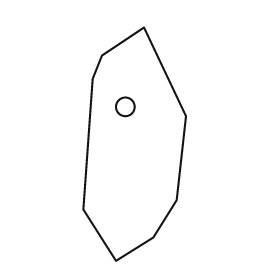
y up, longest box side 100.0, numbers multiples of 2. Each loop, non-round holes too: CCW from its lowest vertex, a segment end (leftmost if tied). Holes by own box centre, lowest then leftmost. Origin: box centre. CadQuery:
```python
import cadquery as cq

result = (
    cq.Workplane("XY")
    .moveTo(-8.0, -50.0)
    .lineTo(8.0, -40.0)
    .lineTo(18.0, -24.0)
    .lineTo(22.0, 12.0)
    .lineTo(4.0, 50.0)
    .lineTo(-14.0, 38.0)
    .lineTo(-18.0, 28.0)
    .lineTo(-22.0, -28.0)
    .close()
    .moveTo(-4.0, 16.0)
    .circle(4.0)
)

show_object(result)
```